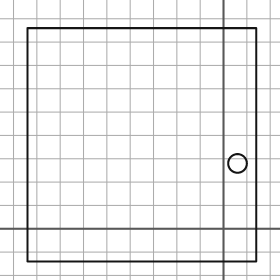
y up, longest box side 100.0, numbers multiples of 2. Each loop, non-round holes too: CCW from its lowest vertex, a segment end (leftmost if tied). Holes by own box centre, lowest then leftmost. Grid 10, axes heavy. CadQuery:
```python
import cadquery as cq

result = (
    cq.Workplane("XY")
    .moveTo(-84.0, -14.0)
    .lineTo(14.0, -14.0)
    .lineTo(14.0, 86.0)
    .lineTo(-84.0, 86.0)
    .close()
    .moveTo(6.0, 28.0)
    .circle(4.0)
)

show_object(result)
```